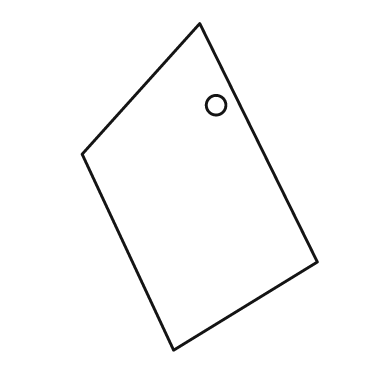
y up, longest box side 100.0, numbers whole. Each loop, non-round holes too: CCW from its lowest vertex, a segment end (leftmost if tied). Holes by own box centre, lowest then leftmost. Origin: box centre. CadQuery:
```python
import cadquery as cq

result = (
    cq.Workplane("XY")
    .moveTo(-8.0, -50.0)
    .lineTo(36.0, -23.0)
    .lineTo(0.0, 50.0)
    .lineTo(-36.0, 10.0)
    .close()
    .moveTo(5.0, 25.0)
    .circle(3.0)
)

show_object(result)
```